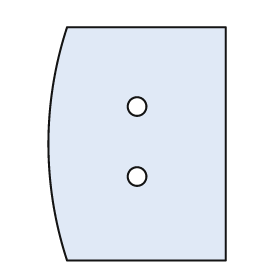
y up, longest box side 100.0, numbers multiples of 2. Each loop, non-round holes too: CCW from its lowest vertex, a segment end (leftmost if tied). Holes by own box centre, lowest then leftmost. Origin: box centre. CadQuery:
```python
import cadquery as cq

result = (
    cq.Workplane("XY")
    .moveTo(-30.0, -50.0)
    .lineTo(38.0, -50.0)
    .lineTo(38.0, 50.0)
    .lineTo(-30.0, 50.0)
    .threePointArc((-38.0, 0.0), (-30.0, -50.0))
    .close()
    .moveTo(0.0, -14.0)
    .circle(4.0)
    .moveTo(0.0, 16.0)
    .circle(4.0)
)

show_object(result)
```